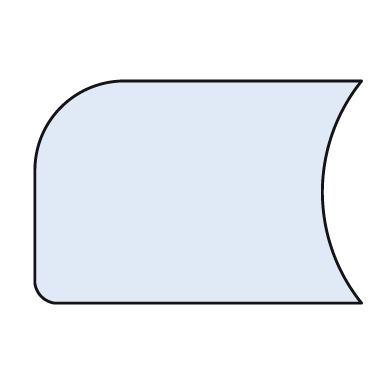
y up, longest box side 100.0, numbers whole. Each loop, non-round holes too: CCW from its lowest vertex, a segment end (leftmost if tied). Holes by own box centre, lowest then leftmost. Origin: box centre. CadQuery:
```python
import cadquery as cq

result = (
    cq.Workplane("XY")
    .moveTo(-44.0, -34.0)
    .lineTo(50.0, -34.0)
    .threePointArc((38.0, 0.0), (50.0, 34.0))
    .lineTo(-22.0, 34.0)
    .threePointArc((-42.0, 26.0), (-50.0, 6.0))
    .lineTo(-50.0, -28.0)
    .threePointArc((-48.0, -32.0), (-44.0, -34.0))
    .close()
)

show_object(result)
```